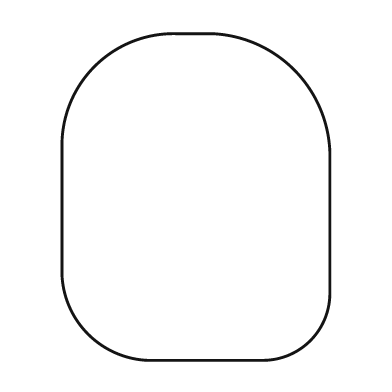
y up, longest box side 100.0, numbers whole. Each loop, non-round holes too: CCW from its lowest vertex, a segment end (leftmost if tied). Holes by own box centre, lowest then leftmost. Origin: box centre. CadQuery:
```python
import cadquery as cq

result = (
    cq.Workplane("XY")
    .moveTo(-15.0, -50.0)
    .lineTo(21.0, -50.0)
    .threePointArc((35.0, -44.0), (41.0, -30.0))
    .lineTo(41.0, 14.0)
    .threePointArc((30.0, 39.0), (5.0, 50.0))
    .lineTo(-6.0, 50.0)
    .threePointArc((-31.0, 40.0), (-41.0, 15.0))
    .lineTo(-41.0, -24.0)
    .threePointArc((-33.0, -42.0), (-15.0, -50.0))
    .close()
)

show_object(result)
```